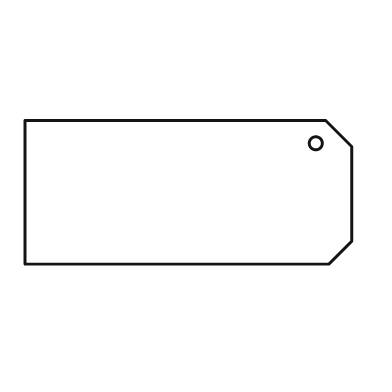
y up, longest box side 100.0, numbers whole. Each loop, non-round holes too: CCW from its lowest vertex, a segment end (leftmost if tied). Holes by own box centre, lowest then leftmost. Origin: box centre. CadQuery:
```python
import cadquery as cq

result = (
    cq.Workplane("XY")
    .moveTo(-50.0, -22.0)
    .lineTo(43.0, -22.0)
    .lineTo(50.0, -15.0)
    .lineTo(50.0, 14.0)
    .lineTo(42.0, 22.0)
    .lineTo(-50.0, 22.0)
    .close()
    .moveTo(39.0, 15.0)
    .circle(2.0)
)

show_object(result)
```